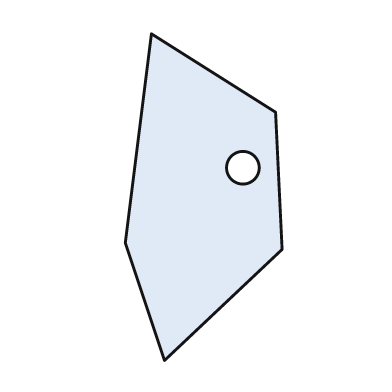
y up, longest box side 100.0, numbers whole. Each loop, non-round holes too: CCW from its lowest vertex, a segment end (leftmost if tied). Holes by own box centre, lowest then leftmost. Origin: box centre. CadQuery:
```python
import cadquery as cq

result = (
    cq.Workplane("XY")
    .moveTo(-12.0, -50.0)
    .lineTo(24.0, -16.0)
    .lineTo(22.0, 26.0)
    .lineTo(-16.0, 50.0)
    .lineTo(-24.0, -14.0)
    .close()
    .moveTo(12.0, 9.0)
    .circle(5.0)
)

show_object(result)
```